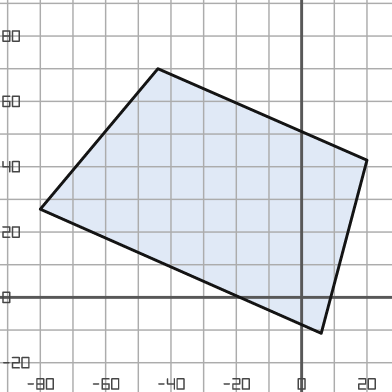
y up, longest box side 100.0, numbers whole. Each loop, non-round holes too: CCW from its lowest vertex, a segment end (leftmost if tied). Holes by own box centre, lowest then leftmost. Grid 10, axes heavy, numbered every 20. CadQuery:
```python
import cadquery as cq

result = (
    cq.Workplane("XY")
    .moveTo(6.0, -11.0)
    .lineTo(20.0, 42.0)
    .lineTo(-44.0, 70.0)
    .lineTo(-80.0, 27.0)
    .close()
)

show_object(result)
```